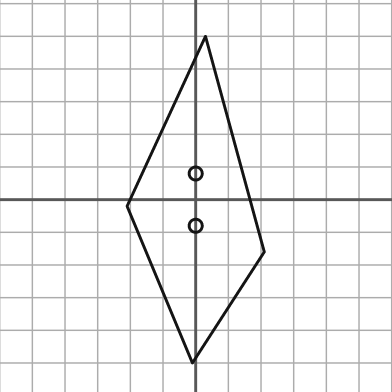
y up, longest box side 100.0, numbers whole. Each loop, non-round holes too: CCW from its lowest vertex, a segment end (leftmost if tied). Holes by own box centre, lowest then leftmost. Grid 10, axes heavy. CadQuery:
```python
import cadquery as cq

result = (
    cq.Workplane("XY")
    .moveTo(-1.0, -50.0)
    .lineTo(21.0, -16.0)
    .lineTo(3.0, 50.0)
    .lineTo(-21.0, -2.0)
    .close()
    .moveTo(0.0, -8.0)
    .circle(2.0)
    .moveTo(0.0, 8.0)
    .circle(2.0)
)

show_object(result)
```